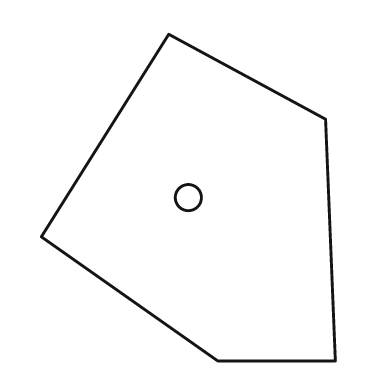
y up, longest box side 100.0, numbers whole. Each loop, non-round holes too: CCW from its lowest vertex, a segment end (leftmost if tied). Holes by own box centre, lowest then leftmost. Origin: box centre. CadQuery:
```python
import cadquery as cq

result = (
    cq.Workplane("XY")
    .moveTo(9.0, -50.0)
    .lineTo(45.0, -50.0)
    .lineTo(42.0, 24.0)
    .lineTo(-6.0, 50.0)
    .lineTo(-45.0, -12.0)
    .close()
    .moveTo(0.0, 0.0)
    .circle(4.0)
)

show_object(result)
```